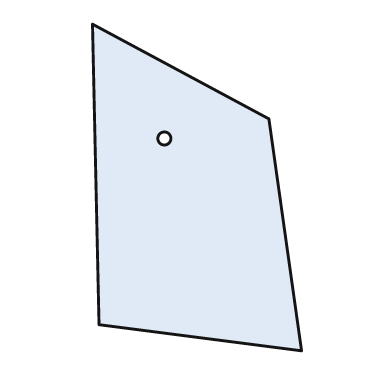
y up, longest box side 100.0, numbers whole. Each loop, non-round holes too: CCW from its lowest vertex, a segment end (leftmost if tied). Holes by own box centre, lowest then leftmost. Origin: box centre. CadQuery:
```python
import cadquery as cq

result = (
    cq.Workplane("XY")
    .moveTo(32.0, -50.0)
    .lineTo(22.0, 21.0)
    .lineTo(-32.0, 50.0)
    .lineTo(-30.0, -42.0)
    .close()
    .moveTo(-10.0, 15.0)
    .circle(2.0)
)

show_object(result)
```